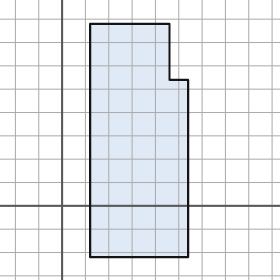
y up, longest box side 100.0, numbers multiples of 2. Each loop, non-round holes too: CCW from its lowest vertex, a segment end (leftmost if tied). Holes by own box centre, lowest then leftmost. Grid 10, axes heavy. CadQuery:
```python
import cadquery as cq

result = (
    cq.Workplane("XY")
    .moveTo(12.0, -22.0)
    .lineTo(54.0, -22.0)
    .lineTo(54.0, 54.0)
    .lineTo(46.0, 54.0)
    .lineTo(46.0, 78.0)
    .lineTo(12.0, 78.0)
    .close()
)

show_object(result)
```